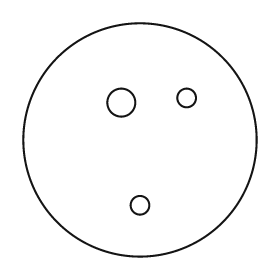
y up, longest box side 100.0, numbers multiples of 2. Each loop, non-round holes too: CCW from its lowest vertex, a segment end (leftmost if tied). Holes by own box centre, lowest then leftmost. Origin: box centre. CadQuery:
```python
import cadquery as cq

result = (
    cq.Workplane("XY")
    .moveTo(0.0, 0.0)
    .circle(50.0)
    .moveTo(0.0, -28.0)
    .circle(4.0)
    .moveTo(-8.0, 16.0)
    .circle(6.0)
    .moveTo(20.0, 18.0)
    .circle(4.0)
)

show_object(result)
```